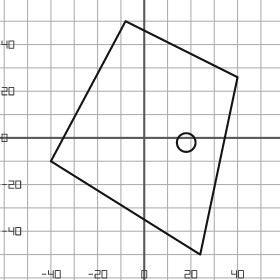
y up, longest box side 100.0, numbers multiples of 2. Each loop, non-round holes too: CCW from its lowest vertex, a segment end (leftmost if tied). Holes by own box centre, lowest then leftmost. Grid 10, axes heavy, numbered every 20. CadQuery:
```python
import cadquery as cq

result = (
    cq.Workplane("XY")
    .moveTo(24.0, -50.0)
    .lineTo(40.0, 26.0)
    .lineTo(-8.0, 50.0)
    .lineTo(-40.0, -10.0)
    .close()
    .moveTo(18.0, -2.0)
    .circle(4.0)
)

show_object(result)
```